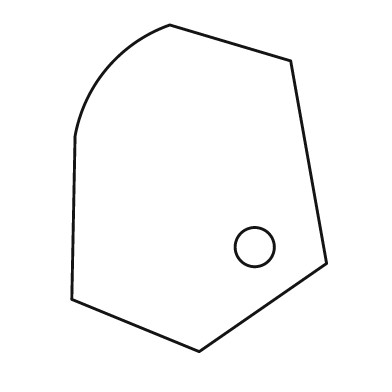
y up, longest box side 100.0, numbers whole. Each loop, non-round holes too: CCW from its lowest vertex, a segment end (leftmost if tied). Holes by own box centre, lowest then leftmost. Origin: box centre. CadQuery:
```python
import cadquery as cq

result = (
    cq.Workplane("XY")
    .moveTo(0.0, -50.0)
    .lineTo(39.0, -23.0)
    .lineTo(28.0, 39.0)
    .lineTo(-9.0, 50.0)
    .threePointArc((-28.0, 37.0), (-38.0, 16.0))
    .lineTo(-39.0, -34.0)
    .close()
    .moveTo(17.0, -18.0)
    .circle(6.0)
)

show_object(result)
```